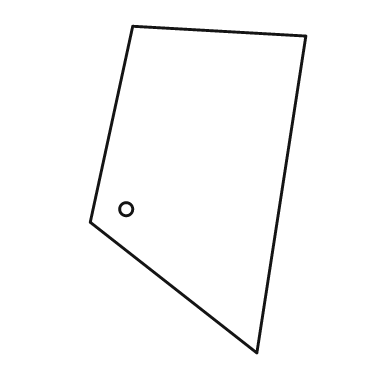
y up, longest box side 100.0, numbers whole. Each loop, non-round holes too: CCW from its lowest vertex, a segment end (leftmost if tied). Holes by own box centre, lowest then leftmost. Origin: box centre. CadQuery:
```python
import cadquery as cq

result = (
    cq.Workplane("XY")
    .moveTo(18.0, -50.0)
    .lineTo(33.0, 47.0)
    .lineTo(-20.0, 50.0)
    .lineTo(-33.0, -10.0)
    .close()
    .moveTo(-22.0, -6.0)
    .circle(2.0)
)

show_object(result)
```